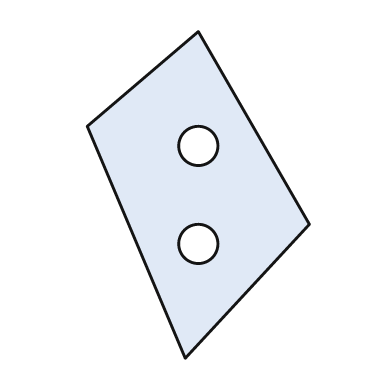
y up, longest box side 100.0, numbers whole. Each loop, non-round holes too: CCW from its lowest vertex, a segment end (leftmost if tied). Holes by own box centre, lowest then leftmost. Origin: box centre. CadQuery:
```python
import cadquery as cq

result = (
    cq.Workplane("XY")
    .moveTo(-4.0, -50.0)
    .lineTo(34.0, -9.0)
    .lineTo(0.0, 50.0)
    .lineTo(-34.0, 21.0)
    .close()
    .moveTo(0.0, -15.0)
    .circle(6.0)
    .moveTo(0.0, 15.0)
    .circle(6.0)
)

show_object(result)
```